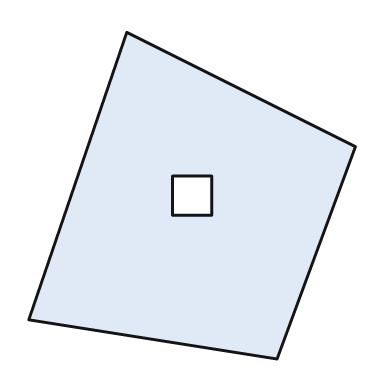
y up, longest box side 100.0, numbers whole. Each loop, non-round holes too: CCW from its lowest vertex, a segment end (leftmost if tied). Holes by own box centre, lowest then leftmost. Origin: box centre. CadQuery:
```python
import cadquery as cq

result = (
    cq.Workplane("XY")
    .moveTo(26.0, -50.0)
    .lineTo(50.0, 15.0)
    .lineTo(-20.0, 50.0)
    .lineTo(-50.0, -38.0)
    .close()
    .moveTo(-6.0, -6.0)
    .lineTo(6.0, -6.0)
    .lineTo(6.0, 6.0)
    .lineTo(-6.0, 6.0)
    .close()
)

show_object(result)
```